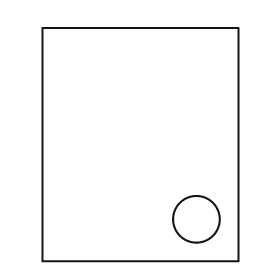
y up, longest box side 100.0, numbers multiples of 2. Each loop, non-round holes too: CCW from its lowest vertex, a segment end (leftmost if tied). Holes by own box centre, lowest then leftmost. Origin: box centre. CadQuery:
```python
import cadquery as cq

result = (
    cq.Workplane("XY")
    .moveTo(-42.0, -50.0)
    .lineTo(42.0, -50.0)
    .lineTo(42.0, 50.0)
    .lineTo(-42.0, 50.0)
    .close()
    .moveTo(24.0, -32.0)
    .circle(10.0)
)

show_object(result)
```